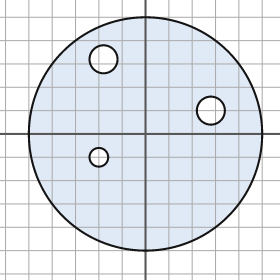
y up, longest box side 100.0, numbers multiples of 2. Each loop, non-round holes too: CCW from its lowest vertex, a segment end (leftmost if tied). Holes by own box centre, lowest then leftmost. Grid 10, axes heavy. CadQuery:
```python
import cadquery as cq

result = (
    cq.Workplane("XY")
    .moveTo(0.0, 0.0)
    .circle(50.0)
    .moveTo(-20.0, -10.0)
    .circle(4.0)
    .moveTo(28.0, 10.0)
    .circle(6.0)
    .moveTo(-18.0, 32.0)
    .circle(6.0)
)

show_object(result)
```